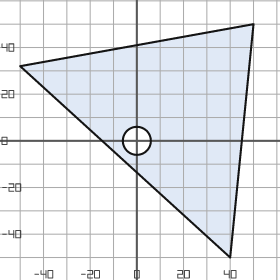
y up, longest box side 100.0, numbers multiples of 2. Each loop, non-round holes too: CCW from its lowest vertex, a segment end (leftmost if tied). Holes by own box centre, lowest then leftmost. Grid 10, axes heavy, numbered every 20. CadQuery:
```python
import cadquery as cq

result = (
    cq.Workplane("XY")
    .moveTo(40.0, -50.0)
    .lineTo(50.0, 50.0)
    .lineTo(-50.0, 32.0)
    .close()
    .moveTo(0.0, 0.0)
    .circle(6.0)
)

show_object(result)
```